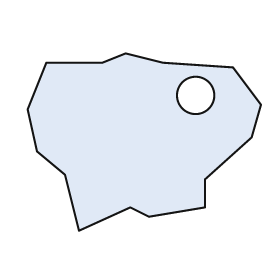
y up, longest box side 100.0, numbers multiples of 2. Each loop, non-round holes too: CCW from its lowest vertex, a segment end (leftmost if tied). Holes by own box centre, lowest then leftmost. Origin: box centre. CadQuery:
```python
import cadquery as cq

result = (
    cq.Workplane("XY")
    .moveTo(-28.0, -38.0)
    .lineTo(-6.0, -28.0)
    .lineTo(2.0, -32.0)
    .lineTo(26.0, -28.0)
    .lineTo(26.0, -16.0)
    .lineTo(46.0, 2.0)
    .lineTo(50.0, 16.0)
    .lineTo(38.0, 32.0)
    .lineTo(8.0, 34.0)
    .lineTo(-8.0, 38.0)
    .lineTo(-18.0, 34.0)
    .lineTo(-42.0, 34.0)
    .lineTo(-50.0, 14.0)
    .lineTo(-46.0, -4.0)
    .lineTo(-34.0, -14.0)
    .close()
    .moveTo(22.0, 20.0)
    .circle(8.0)
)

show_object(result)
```